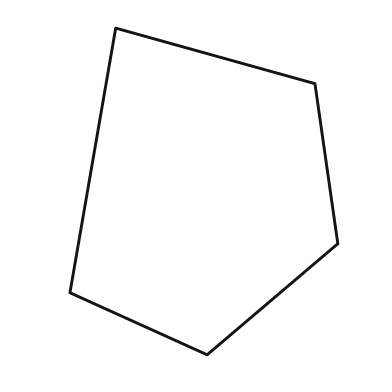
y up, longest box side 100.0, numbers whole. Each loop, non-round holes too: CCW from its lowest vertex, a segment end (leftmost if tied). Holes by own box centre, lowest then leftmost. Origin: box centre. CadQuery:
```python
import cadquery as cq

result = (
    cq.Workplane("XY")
    .moveTo(1.0, -50.0)
    .lineTo(41.0, -16.0)
    .lineTo(34.0, 33.0)
    .lineTo(-27.0, 50.0)
    .lineTo(-41.0, -31.0)
    .close()
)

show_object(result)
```